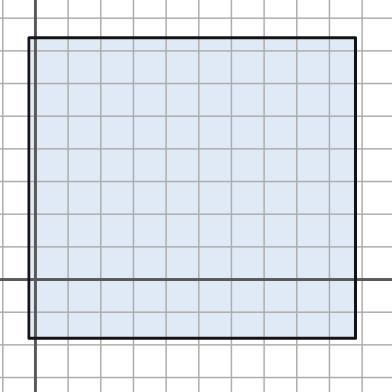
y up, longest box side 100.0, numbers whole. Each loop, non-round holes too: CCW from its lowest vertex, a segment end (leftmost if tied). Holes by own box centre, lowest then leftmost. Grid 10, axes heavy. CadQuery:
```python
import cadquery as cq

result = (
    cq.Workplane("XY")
    .moveTo(-2.0, -18.0)
    .lineTo(98.0, -18.0)
    .lineTo(98.0, 74.0)
    .lineTo(-2.0, 74.0)
    .close()
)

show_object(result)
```